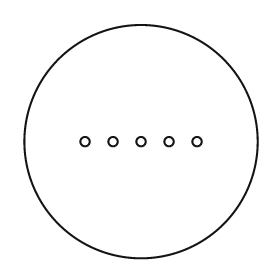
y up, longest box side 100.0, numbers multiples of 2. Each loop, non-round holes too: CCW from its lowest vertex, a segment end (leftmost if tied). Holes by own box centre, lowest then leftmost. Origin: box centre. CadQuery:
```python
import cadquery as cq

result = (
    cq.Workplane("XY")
    .moveTo(0.0, 0.0)
    .circle(50.0)
    .moveTo(-24.0, 0.0)
    .circle(2.0)
    .moveTo(-12.0, 0.0)
    .circle(2.0)
    .moveTo(0.0, 0.0)
    .circle(2.0)
    .moveTo(12.0, 0.0)
    .circle(2.0)
    .moveTo(24.0, 0.0)
    .circle(2.0)
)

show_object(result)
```